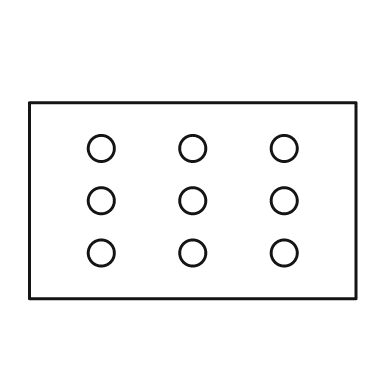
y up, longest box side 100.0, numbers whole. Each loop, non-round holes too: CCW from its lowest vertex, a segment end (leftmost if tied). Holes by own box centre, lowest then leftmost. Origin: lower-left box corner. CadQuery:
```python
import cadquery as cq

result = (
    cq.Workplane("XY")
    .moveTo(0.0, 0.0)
    .lineTo(100.0, 0.0)
    .lineTo(100.0, 60.0)
    .lineTo(0.0, 60.0)
    .close()
    .moveTo(22.0, 14.0)
    .circle(4.0)
    .moveTo(50.0, 14.0)
    .circle(4.0)
    .moveTo(78.0, 14.0)
    .circle(4.0)
    .moveTo(22.0, 30.0)
    .circle(4.0)
    .moveTo(50.0, 30.0)
    .circle(4.0)
    .moveTo(78.0, 30.0)
    .circle(4.0)
    .moveTo(22.0, 46.0)
    .circle(4.0)
    .moveTo(50.0, 46.0)
    .circle(4.0)
    .moveTo(78.0, 46.0)
    .circle(4.0)
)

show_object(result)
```